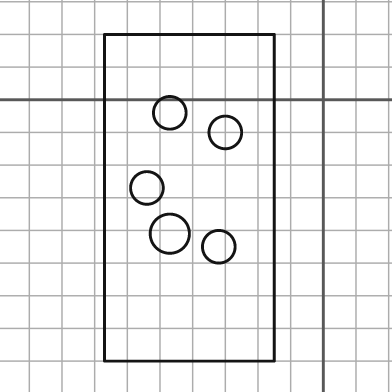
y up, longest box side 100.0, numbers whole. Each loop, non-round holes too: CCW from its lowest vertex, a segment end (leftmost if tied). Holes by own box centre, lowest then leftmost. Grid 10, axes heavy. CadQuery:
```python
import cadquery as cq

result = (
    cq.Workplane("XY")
    .moveTo(-67.0, -80.0)
    .lineTo(-15.0, -80.0)
    .lineTo(-15.0, 20.0)
    .lineTo(-67.0, 20.0)
    .close()
    .moveTo(-32.0, -45.0)
    .circle(5.0)
    .moveTo(-47.0, -41.0)
    .circle(6.0)
    .moveTo(-54.0, -27.0)
    .circle(5.0)
    .moveTo(-30.0, -10.0)
    .circle(5.0)
    .moveTo(-47.0, -4.0)
    .circle(5.0)
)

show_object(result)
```